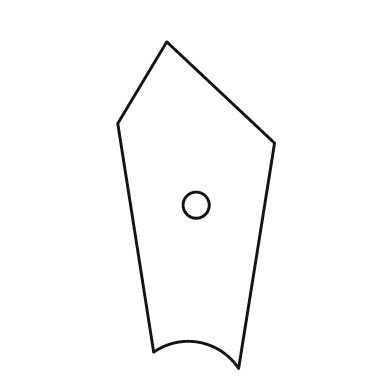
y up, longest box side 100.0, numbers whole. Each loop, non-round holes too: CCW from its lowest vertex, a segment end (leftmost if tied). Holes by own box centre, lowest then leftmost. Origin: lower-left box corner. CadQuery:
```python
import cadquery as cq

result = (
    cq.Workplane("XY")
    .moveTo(37.0, 0.0)
    .lineTo(48.0, 69.0)
    .lineTo(15.0, 100.0)
    .lineTo(0.0, 75.0)
    .lineTo(11.0, 5.0)
    .threePointArc((25.0, 8.0), (37.0, 0.0))
    .close()
    .moveTo(24.0, 50.0)
    .circle(4.0)
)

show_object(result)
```